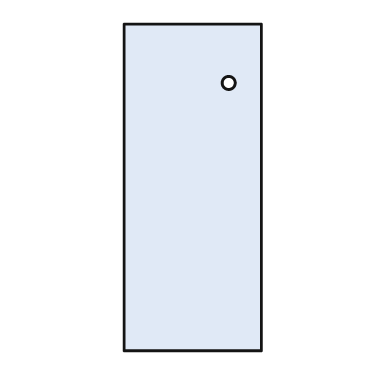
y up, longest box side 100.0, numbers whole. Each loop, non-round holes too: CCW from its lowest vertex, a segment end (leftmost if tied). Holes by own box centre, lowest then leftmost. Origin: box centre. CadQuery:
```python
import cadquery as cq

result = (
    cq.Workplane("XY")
    .moveTo(-21.0, -50.0)
    .lineTo(21.0, -50.0)
    .lineTo(21.0, 50.0)
    .lineTo(-21.0, 50.0)
    .close()
    .moveTo(11.0, 32.0)
    .circle(2.0)
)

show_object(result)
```